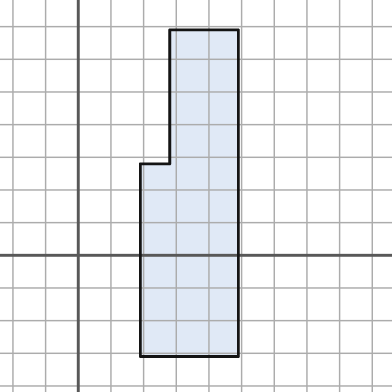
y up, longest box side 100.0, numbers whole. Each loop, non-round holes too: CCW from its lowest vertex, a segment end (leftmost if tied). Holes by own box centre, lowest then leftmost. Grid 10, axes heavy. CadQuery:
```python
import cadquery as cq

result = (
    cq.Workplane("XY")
    .moveTo(19.0, -31.0)
    .lineTo(49.0, -31.0)
    .lineTo(49.0, 69.0)
    .lineTo(28.0, 69.0)
    .lineTo(28.0, 28.0)
    .lineTo(19.0, 28.0)
    .close()
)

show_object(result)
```